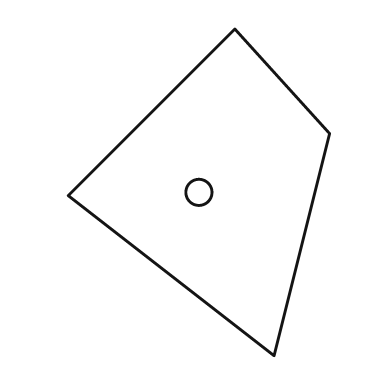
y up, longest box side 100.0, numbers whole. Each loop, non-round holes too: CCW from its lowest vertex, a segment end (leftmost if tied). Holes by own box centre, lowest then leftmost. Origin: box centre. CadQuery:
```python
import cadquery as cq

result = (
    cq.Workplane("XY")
    .moveTo(23.0, -50.0)
    .lineTo(40.0, 18.0)
    .lineTo(11.0, 50.0)
    .lineTo(-40.0, -1.0)
    .close()
    .moveTo(0.0, 0.0)
    .circle(4.0)
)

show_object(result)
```